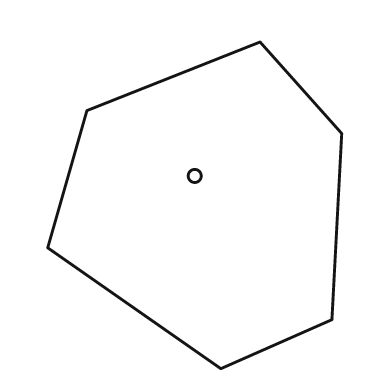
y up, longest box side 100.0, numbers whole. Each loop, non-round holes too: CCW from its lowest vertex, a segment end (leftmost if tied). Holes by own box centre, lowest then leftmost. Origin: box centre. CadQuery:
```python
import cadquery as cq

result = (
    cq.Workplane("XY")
    .moveTo(8.0, -50.0)
    .lineTo(42.0, -35.0)
    .lineTo(45.0, 22.0)
    .lineTo(20.0, 50.0)
    .lineTo(-33.0, 29.0)
    .lineTo(-45.0, -13.0)
    .close()
    .moveTo(0.0, 9.0)
    .circle(2.0)
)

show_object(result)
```